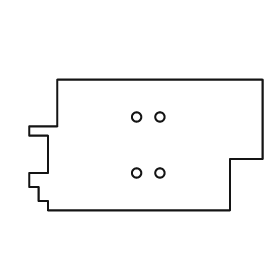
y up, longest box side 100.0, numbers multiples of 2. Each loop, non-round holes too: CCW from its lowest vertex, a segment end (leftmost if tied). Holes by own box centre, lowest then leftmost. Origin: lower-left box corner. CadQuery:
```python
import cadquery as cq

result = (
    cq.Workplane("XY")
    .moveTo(8.0, 0.0)
    .lineTo(86.0, 0.0)
    .lineTo(86.0, 22.0)
    .lineTo(100.0, 22.0)
    .lineTo(100.0, 56.0)
    .lineTo(12.0, 56.0)
    .lineTo(12.0, 36.0)
    .lineTo(0.0, 36.0)
    .lineTo(0.0, 32.0)
    .lineTo(8.0, 32.0)
    .lineTo(8.0, 16.0)
    .lineTo(0.0, 16.0)
    .lineTo(0.0, 10.0)
    .lineTo(4.0, 10.0)
    .lineTo(4.0, 4.0)
    .lineTo(8.0, 4.0)
    .close()
    .moveTo(46.0, 16.0)
    .circle(2.0)
    .moveTo(56.0, 16.0)
    .circle(2.0)
    .moveTo(46.0, 40.0)
    .circle(2.0)
    .moveTo(56.0, 40.0)
    .circle(2.0)
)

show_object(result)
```